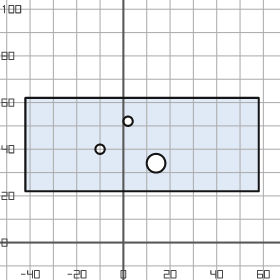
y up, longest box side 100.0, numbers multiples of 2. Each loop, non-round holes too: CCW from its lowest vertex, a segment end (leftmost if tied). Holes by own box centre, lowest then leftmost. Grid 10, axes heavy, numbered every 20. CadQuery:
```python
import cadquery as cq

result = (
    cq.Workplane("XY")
    .moveTo(-42.0, 22.0)
    .lineTo(58.0, 22.0)
    .lineTo(58.0, 62.0)
    .lineTo(-42.0, 62.0)
    .close()
    .moveTo(14.0, 34.0)
    .circle(4.0)
    .moveTo(-10.0, 40.0)
    .circle(2.0)
    .moveTo(2.0, 52.0)
    .circle(2.0)
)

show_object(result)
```